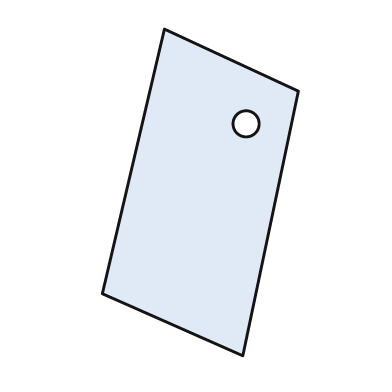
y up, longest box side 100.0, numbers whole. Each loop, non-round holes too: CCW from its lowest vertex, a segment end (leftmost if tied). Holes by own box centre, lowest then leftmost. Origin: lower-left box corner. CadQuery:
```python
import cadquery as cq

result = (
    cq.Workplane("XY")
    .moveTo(43.0, 0.0)
    .lineTo(60.0, 81.0)
    .lineTo(19.0, 100.0)
    .lineTo(0.0, 19.0)
    .close()
    .moveTo(44.0, 71.0)
    .circle(4.0)
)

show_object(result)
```